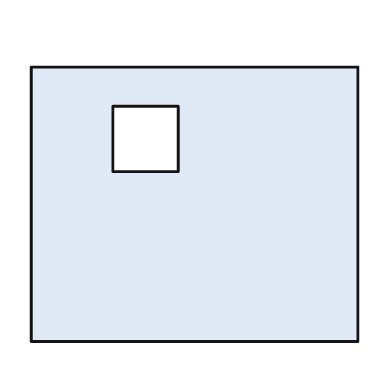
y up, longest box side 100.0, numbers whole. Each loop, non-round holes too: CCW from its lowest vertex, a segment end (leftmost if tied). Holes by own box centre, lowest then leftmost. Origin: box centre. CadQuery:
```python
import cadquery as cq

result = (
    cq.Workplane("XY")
    .moveTo(-50.0, -42.0)
    .lineTo(50.0, -42.0)
    .lineTo(50.0, 42.0)
    .lineTo(-50.0, 42.0)
    .close()
    .moveTo(-25.0, 10.0)
    .lineTo(-5.0, 10.0)
    .lineTo(-5.0, 30.0)
    .lineTo(-25.0, 30.0)
    .close()
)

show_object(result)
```